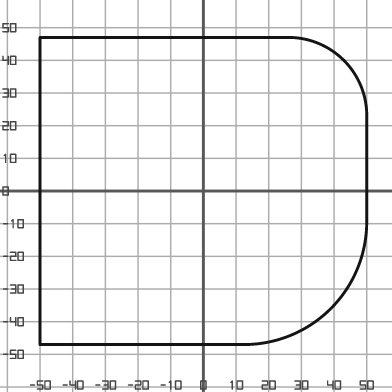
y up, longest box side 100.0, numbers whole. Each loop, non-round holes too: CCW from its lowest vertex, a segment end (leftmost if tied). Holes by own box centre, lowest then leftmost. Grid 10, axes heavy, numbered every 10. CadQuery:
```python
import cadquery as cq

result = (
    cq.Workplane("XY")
    .moveTo(-50.0, -47.0)
    .lineTo(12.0, -47.0)
    .threePointArc((39.0, -36.0), (50.0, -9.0))
    .lineTo(50.0, 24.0)
    .threePointArc((43.0, 40.0), (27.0, 47.0))
    .lineTo(-50.0, 47.0)
    .close()
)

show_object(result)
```